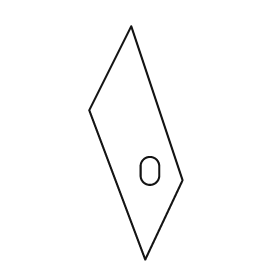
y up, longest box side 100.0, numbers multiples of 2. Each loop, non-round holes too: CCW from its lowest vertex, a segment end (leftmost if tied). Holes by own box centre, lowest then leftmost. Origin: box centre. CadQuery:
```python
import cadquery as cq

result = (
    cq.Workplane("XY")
    .moveTo(4.0, -50.0)
    .lineTo(20.0, -16.0)
    .lineTo(-2.0, 50.0)
    .lineTo(-20.0, 14.0)
    .close()
    .moveTo(2.0, -14.0)
    .threePointArc((6.0, -18.0), (10.0, -14.0))
    .lineTo(10.0, -10.0)
    .threePointArc((6.0, -6.0), (2.0, -10.0))
    .close()
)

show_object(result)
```